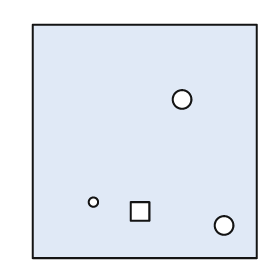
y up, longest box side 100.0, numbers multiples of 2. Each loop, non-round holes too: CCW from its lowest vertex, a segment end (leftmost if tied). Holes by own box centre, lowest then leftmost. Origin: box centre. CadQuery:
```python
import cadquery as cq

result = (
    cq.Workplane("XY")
    .moveTo(-48.0, -50.0)
    .lineTo(48.0, -50.0)
    .lineTo(48.0, 50.0)
    .lineTo(-48.0, 50.0)
    .close()
    .moveTo(34.0, -36.0)
    .circle(4.0)
    .moveTo(-6.0, -34.0)
    .lineTo(2.0, -34.0)
    .lineTo(2.0, -26.0)
    .lineTo(-6.0, -26.0)
    .close()
    .moveTo(-22.0, -26.0)
    .circle(2.0)
    .moveTo(16.0, 18.0)
    .circle(4.0)
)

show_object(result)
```